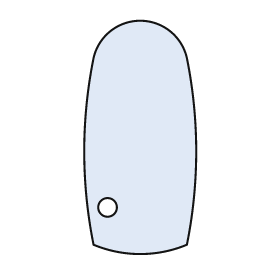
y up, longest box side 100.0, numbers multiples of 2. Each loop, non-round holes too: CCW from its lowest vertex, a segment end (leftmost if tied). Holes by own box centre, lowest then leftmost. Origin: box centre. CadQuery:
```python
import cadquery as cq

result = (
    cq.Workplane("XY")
    .moveTo(-20.0, -46.0)
    .threePointArc((0.0, -50.0), (20.0, -46.0))
    .threePointArc((24.0, -6.0), (20.0, 34.0))
    .threePointArc((0.0, 50.0), (-20.0, 34.0))
    .threePointArc((-24.0, -6.0), (-20.0, -46.0))
    .close()
    .moveTo(-14.0, -30.0)
    .circle(4.0)
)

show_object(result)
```